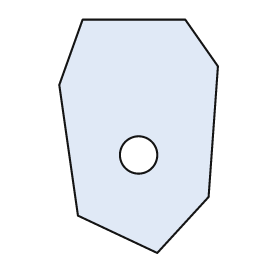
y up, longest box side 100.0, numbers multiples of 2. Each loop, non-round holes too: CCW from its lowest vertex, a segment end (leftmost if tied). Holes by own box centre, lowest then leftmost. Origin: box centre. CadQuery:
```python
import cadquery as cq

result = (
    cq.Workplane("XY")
    .moveTo(8.0, -50.0)
    .lineTo(30.0, -26.0)
    .lineTo(34.0, 30.0)
    .lineTo(20.0, 50.0)
    .lineTo(-24.0, 50.0)
    .lineTo(-34.0, 22.0)
    .lineTo(-26.0, -34.0)
    .close()
    .moveTo(0.0, -8.0)
    .circle(8.0)
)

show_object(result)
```